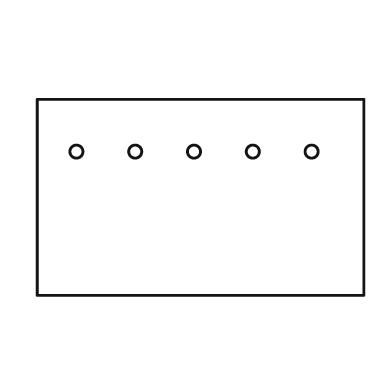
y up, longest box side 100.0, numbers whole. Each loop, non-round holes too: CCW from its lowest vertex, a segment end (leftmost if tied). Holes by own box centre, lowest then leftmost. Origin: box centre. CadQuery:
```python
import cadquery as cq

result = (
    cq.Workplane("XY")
    .moveTo(-50.0, -30.0)
    .lineTo(50.0, -30.0)
    .lineTo(50.0, 30.0)
    .lineTo(-50.0, 30.0)
    .close()
    .moveTo(-38.0, 14.0)
    .circle(2.0)
    .moveTo(-20.0, 14.0)
    .circle(2.0)
    .moveTo(-2.0, 14.0)
    .circle(2.0)
    .moveTo(16.0, 14.0)
    .circle(2.0)
    .moveTo(34.0, 14.0)
    .circle(2.0)
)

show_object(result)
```